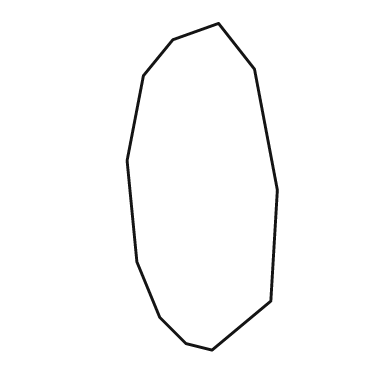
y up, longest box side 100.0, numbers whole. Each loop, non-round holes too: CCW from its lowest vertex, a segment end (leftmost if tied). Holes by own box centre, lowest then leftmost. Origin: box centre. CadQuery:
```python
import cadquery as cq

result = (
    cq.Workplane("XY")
    .moveTo(3.0, -50.0)
    .lineTo(21.0, -35.0)
    .lineTo(23.0, -1.0)
    .lineTo(16.0, 36.0)
    .lineTo(5.0, 50.0)
    .lineTo(-9.0, 45.0)
    .lineTo(-18.0, 34.0)
    .lineTo(-23.0, 8.0)
    .lineTo(-20.0, -23.0)
    .lineTo(-13.0, -40.0)
    .lineTo(-5.0, -48.0)
    .close()
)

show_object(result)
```